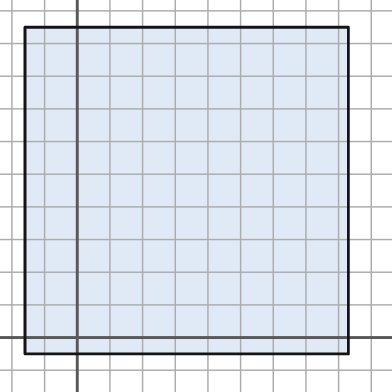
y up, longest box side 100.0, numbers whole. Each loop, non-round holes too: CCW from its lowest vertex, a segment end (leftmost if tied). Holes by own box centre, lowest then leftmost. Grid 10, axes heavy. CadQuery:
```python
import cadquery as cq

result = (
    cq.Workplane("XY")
    .moveTo(-16.0, -5.0)
    .lineTo(83.0, -5.0)
    .lineTo(83.0, 95.0)
    .lineTo(-16.0, 95.0)
    .close()
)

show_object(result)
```